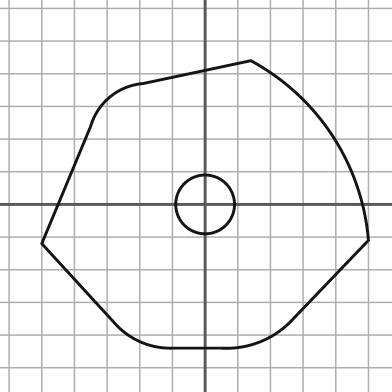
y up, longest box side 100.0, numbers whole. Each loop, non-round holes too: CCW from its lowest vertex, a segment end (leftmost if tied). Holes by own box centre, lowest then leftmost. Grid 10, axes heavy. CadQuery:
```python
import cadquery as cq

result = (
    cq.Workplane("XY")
    .moveTo(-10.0, -44.0)
    .lineTo(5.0, -44.0)
    .threePointArc((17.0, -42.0), (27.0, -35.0))
    .lineTo(50.0, -11.0)
    .threePointArc((39.0, 21.0), (14.0, 44.0))
    .lineTo(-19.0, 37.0)
    .threePointArc((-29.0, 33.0), (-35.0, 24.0))
    .lineTo(-50.0, -12.0)
    .lineTo(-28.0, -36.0)
    .threePointArc((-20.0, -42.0), (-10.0, -44.0))
    .close()
    .moveTo(0.0, 0.0)
    .circle(9.0)
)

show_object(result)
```